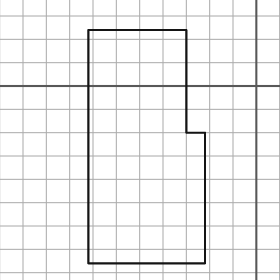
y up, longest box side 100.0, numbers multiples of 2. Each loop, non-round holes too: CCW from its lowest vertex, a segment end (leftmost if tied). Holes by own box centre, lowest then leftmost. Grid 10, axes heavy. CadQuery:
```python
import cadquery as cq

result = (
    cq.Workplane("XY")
    .moveTo(-72.0, -76.0)
    .lineTo(-22.0, -76.0)
    .lineTo(-22.0, -20.0)
    .lineTo(-30.0, -20.0)
    .lineTo(-30.0, 24.0)
    .lineTo(-72.0, 24.0)
    .close()
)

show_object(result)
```